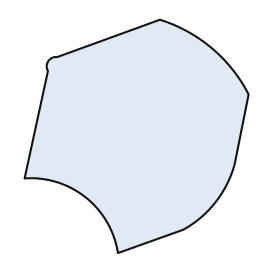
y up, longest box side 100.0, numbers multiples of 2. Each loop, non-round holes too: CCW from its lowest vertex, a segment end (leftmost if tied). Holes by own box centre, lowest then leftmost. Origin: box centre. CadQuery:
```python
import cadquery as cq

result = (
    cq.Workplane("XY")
    .moveTo(-8.0, -50.0)
    .lineTo(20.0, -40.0)
    .threePointArc((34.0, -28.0), (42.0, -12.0))
    .lineTo(48.0, 18.0)
    .threePointArc((32.0, 38.0), (10.0, 50.0))
    .lineTo(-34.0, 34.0)
    .threePointArc((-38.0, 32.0), (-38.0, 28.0))
    .lineTo(-48.0, -18.0)
    .threePointArc((-22.0, -26.0), (-8.0, -50.0))
    .close()
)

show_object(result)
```